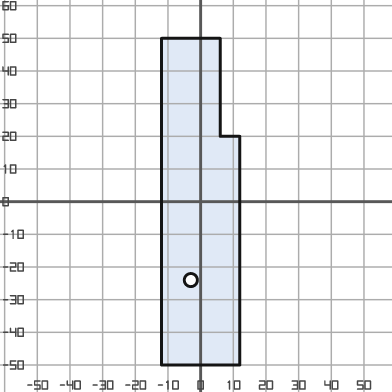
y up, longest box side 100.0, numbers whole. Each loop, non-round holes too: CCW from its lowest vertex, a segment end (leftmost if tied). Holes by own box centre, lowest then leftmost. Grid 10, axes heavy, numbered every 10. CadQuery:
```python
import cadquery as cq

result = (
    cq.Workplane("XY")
    .moveTo(-12.0, -50.0)
    .lineTo(12.0, -50.0)
    .lineTo(12.0, 20.0)
    .lineTo(6.0, 20.0)
    .lineTo(6.0, 50.0)
    .lineTo(-12.0, 50.0)
    .close()
    .moveTo(-3.0, -24.0)
    .circle(2.0)
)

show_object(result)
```